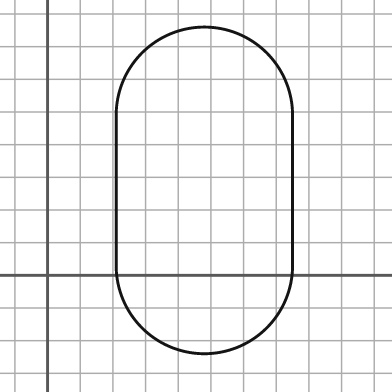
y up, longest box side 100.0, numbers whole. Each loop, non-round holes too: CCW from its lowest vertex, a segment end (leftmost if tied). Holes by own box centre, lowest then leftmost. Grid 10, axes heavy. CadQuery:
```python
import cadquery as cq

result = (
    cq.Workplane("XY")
    .moveTo(21.0, 3.0)
    .threePointArc((48.0, -24.0), (75.0, 3.0))
    .lineTo(75.0, 49.0)
    .threePointArc((48.0, 76.0), (21.0, 49.0))
    .close()
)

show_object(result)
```